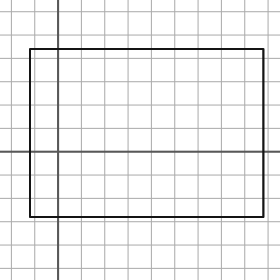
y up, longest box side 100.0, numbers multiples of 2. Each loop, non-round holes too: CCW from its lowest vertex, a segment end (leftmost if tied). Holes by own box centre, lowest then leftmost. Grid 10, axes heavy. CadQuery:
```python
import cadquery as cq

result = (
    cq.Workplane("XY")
    .moveTo(-12.0, -28.0)
    .lineTo(88.0, -28.0)
    .lineTo(88.0, 44.0)
    .lineTo(-12.0, 44.0)
    .close()
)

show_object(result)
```